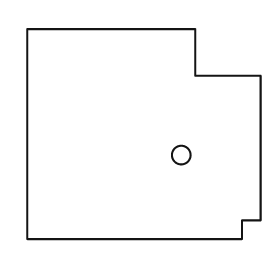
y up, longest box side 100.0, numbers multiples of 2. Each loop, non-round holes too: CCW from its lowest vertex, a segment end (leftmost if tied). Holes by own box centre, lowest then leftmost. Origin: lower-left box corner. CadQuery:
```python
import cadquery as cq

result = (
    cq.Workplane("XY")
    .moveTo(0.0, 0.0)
    .lineTo(92.0, 0.0)
    .lineTo(92.0, 8.0)
    .lineTo(100.0, 8.0)
    .lineTo(100.0, 70.0)
    .lineTo(72.0, 70.0)
    .lineTo(72.0, 90.0)
    .lineTo(0.0, 90.0)
    .close()
    .moveTo(66.0, 36.0)
    .circle(4.0)
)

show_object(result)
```